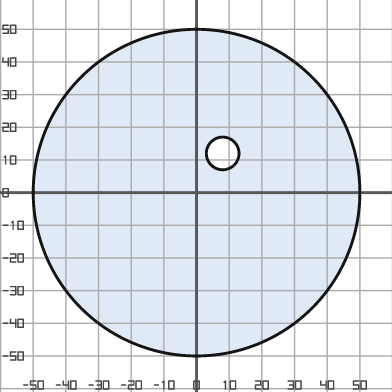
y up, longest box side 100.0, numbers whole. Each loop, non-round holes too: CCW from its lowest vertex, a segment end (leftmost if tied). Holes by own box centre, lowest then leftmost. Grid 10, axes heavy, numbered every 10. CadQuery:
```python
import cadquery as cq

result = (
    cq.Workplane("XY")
    .moveTo(0.0, 0.0)
    .circle(50.0)
    .moveTo(8.0, 12.0)
    .circle(5.0)
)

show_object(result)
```